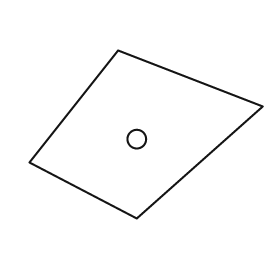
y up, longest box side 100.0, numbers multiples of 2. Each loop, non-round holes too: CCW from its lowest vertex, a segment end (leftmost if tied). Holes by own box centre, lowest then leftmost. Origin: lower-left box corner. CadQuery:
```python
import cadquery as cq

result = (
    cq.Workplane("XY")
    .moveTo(46.0, 0.0)
    .lineTo(100.0, 48.0)
    .lineTo(38.0, 72.0)
    .lineTo(0.0, 24.0)
    .close()
    .moveTo(46.0, 34.0)
    .circle(4.0)
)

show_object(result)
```